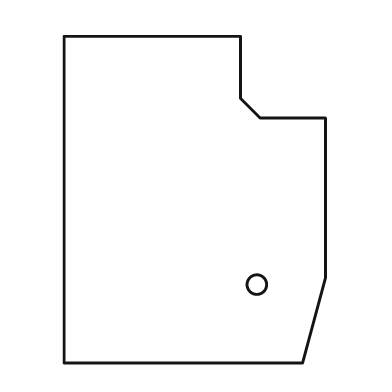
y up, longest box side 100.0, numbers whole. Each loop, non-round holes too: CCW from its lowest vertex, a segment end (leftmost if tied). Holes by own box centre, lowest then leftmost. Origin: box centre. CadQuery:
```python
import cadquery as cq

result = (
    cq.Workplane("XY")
    .moveTo(-40.0, -50.0)
    .lineTo(33.0, -50.0)
    .lineTo(40.0, -24.0)
    .lineTo(40.0, 25.0)
    .lineTo(20.0, 25.0)
    .lineTo(14.0, 31.0)
    .lineTo(14.0, 50.0)
    .lineTo(-40.0, 50.0)
    .close()
    .moveTo(19.0, -26.0)
    .circle(3.0)
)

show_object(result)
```